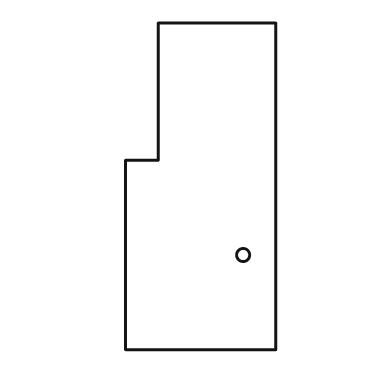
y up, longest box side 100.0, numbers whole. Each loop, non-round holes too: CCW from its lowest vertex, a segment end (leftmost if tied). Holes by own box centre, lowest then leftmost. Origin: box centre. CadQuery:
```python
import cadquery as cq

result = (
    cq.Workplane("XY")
    .moveTo(-23.0, -50.0)
    .lineTo(23.0, -50.0)
    .lineTo(23.0, 50.0)
    .lineTo(-13.0, 50.0)
    .lineTo(-13.0, 8.0)
    .lineTo(-23.0, 8.0)
    .close()
    .moveTo(13.0, -21.0)
    .circle(2.0)
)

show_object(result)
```